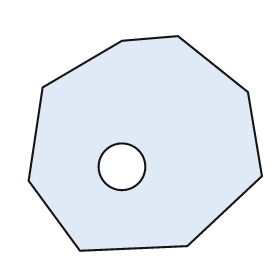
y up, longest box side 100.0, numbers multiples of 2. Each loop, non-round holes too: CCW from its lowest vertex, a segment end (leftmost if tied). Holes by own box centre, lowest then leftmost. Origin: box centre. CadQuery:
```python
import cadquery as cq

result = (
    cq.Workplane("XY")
    .moveTo(-28.0, -46.0)
    .lineTo(18.0, -44.0)
    .lineTo(50.0, -14.0)
    .lineTo(44.0, 22.0)
    .lineTo(14.0, 46.0)
    .lineTo(-10.0, 44.0)
    .lineTo(-44.0, 24.0)
    .lineTo(-50.0, -16.0)
    .close()
    .moveTo(-10.0, -10.0)
    .circle(10.0)
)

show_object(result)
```